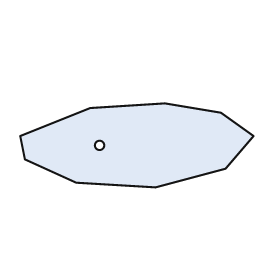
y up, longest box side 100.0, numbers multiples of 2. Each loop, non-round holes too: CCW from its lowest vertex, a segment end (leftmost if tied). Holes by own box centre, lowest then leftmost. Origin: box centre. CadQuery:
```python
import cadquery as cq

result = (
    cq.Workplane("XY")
    .moveTo(8.0, -18.0)
    .lineTo(38.0, -10.0)
    .lineTo(50.0, 4.0)
    .lineTo(36.0, 14.0)
    .lineTo(12.0, 18.0)
    .lineTo(-20.0, 16.0)
    .lineTo(-50.0, 4.0)
    .lineTo(-48.0, -6.0)
    .lineTo(-26.0, -16.0)
    .close()
    .moveTo(-16.0, 0.0)
    .circle(2.0)
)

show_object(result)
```